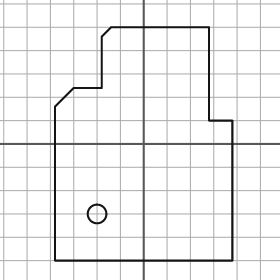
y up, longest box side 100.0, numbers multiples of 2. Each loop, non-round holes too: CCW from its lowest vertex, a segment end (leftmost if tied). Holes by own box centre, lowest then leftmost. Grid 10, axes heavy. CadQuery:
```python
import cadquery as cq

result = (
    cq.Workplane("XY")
    .moveTo(-38.0, -50.0)
    .lineTo(38.0, -50.0)
    .lineTo(38.0, 10.0)
    .lineTo(28.0, 10.0)
    .lineTo(28.0, 50.0)
    .lineTo(-14.0, 50.0)
    .lineTo(-18.0, 46.0)
    .lineTo(-18.0, 24.0)
    .lineTo(-30.0, 24.0)
    .lineTo(-38.0, 16.0)
    .close()
    .moveTo(-20.0, -30.0)
    .circle(4.0)
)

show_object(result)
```